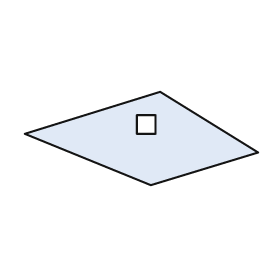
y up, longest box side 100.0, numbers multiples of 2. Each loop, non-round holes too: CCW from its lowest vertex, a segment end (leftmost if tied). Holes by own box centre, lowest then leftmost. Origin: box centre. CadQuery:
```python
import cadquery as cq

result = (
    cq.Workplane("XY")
    .moveTo(4.0, -20.0)
    .lineTo(50.0, -6.0)
    .lineTo(8.0, 20.0)
    .lineTo(-50.0, 2.0)
    .close()
    .moveTo(-2.0, 2.0)
    .lineTo(6.0, 2.0)
    .lineTo(6.0, 10.0)
    .lineTo(-2.0, 10.0)
    .close()
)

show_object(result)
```